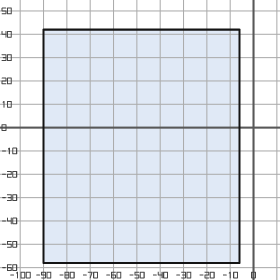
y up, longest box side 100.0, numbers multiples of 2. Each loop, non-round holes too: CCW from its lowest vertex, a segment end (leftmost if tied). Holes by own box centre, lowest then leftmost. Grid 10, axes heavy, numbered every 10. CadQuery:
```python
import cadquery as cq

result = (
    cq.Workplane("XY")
    .moveTo(-90.0, -58.0)
    .lineTo(-6.0, -58.0)
    .lineTo(-6.0, 42.0)
    .lineTo(-90.0, 42.0)
    .close()
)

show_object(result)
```